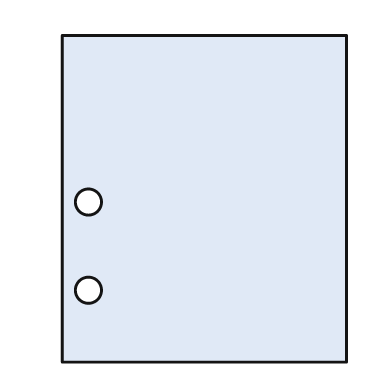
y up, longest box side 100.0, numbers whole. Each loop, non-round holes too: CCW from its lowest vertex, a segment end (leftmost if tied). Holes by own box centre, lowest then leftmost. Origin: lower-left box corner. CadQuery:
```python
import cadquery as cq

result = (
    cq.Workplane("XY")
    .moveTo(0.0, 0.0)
    .lineTo(87.0, 0.0)
    .lineTo(87.0, 100.0)
    .lineTo(0.0, 100.0)
    .close()
    .moveTo(8.0, 22.0)
    .circle(4.0)
    .moveTo(8.0, 49.0)
    .circle(4.0)
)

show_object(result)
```